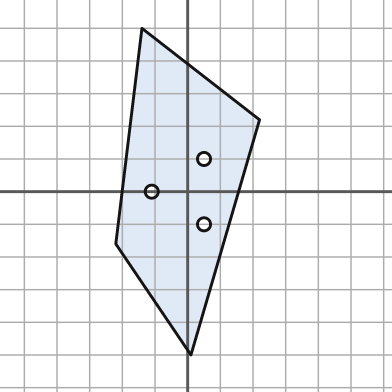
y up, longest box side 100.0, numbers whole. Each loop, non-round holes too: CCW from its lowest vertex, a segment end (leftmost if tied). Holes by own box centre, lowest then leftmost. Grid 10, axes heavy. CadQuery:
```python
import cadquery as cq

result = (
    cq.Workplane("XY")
    .moveTo(1.0, -50.0)
    .lineTo(22.0, 22.0)
    .lineTo(-14.0, 50.0)
    .lineTo(-22.0, -16.0)
    .close()
    .moveTo(5.0, -10.0)
    .circle(2.0)
    .moveTo(-11.0, 0.0)
    .circle(2.0)
    .moveTo(5.0, 10.0)
    .circle(2.0)
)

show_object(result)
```